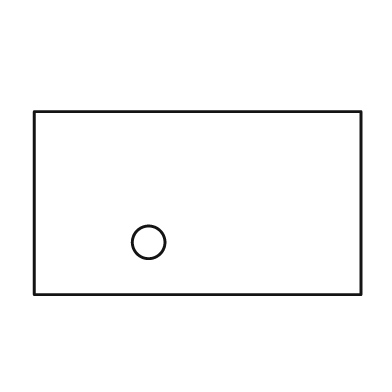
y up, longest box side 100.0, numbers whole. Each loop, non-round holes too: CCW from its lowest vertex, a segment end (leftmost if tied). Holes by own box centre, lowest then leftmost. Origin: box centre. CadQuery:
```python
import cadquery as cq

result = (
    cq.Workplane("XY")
    .moveTo(-50.0, -28.0)
    .lineTo(50.0, -28.0)
    .lineTo(50.0, 28.0)
    .lineTo(-50.0, 28.0)
    .close()
    .moveTo(-15.0, -12.0)
    .circle(5.0)
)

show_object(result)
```